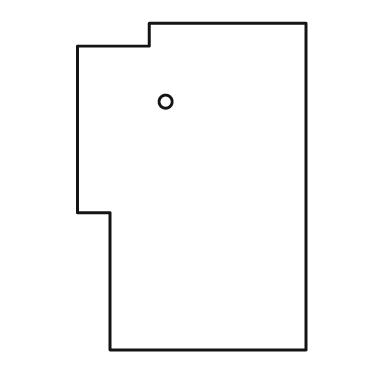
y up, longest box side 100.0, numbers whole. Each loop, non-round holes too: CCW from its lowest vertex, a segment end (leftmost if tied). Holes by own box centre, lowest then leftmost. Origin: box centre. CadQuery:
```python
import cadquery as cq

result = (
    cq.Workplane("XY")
    .moveTo(-25.0, -50.0)
    .lineTo(35.0, -50.0)
    .lineTo(35.0, 50.0)
    .lineTo(-13.0, 50.0)
    .lineTo(-13.0, 43.0)
    .lineTo(-35.0, 43.0)
    .lineTo(-35.0, -8.0)
    .lineTo(-25.0, -8.0)
    .close()
    .moveTo(-8.0, 26.0)
    .circle(2.0)
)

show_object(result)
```